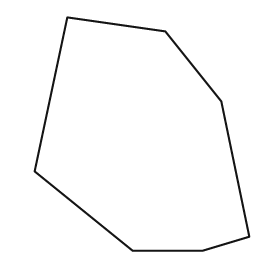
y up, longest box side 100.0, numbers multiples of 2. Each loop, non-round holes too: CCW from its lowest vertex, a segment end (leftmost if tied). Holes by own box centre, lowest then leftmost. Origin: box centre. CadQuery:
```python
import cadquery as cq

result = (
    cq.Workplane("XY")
    .moveTo(-4.0, -50.0)
    .lineTo(26.0, -50.0)
    .lineTo(46.0, -44.0)
    .lineTo(34.0, 14.0)
    .lineTo(10.0, 44.0)
    .lineTo(-32.0, 50.0)
    .lineTo(-46.0, -16.0)
    .close()
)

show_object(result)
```